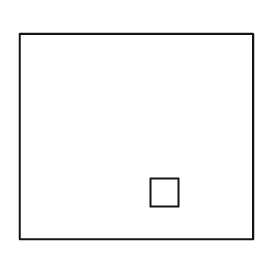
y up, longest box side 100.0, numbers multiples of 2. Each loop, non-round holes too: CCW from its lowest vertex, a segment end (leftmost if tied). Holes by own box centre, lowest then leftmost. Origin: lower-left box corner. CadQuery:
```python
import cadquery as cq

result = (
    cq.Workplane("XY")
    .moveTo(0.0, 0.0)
    .lineTo(100.0, 0.0)
    .lineTo(100.0, 88.0)
    .lineTo(0.0, 88.0)
    .close()
    .moveTo(56.0, 14.0)
    .lineTo(68.0, 14.0)
    .lineTo(68.0, 26.0)
    .lineTo(56.0, 26.0)
    .close()
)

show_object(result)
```